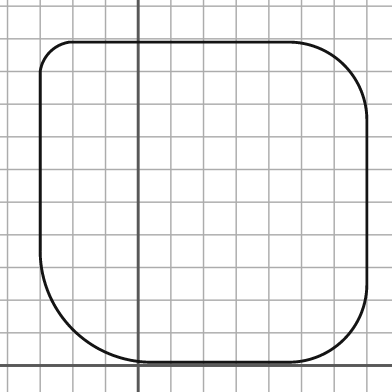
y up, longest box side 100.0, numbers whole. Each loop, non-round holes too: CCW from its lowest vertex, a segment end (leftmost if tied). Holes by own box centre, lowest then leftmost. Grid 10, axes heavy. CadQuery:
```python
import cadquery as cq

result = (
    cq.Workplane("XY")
    .moveTo(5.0, 1.0)
    .lineTo(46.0, 1.0)
    .threePointArc((63.0, 8.0), (70.0, 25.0))
    .lineTo(70.0, 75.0)
    .threePointArc((63.0, 92.0), (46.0, 99.0))
    .lineTo(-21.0, 99.0)
    .threePointArc((-27.0, 96.0), (-30.0, 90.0))
    .lineTo(-30.0, 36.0)
    .threePointArc((-20.0, 11.0), (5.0, 1.0))
    .close()
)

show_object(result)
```